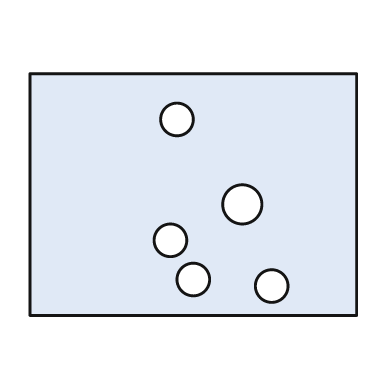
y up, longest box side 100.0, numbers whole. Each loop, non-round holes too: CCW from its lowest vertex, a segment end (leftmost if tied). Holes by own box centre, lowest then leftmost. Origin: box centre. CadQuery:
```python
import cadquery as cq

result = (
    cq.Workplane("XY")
    .moveTo(-50.0, -37.0)
    .lineTo(50.0, -37.0)
    .lineTo(50.0, 37.0)
    .lineTo(-50.0, 37.0)
    .close()
    .moveTo(24.0, -28.0)
    .circle(5.0)
    .moveTo(0.0, -26.0)
    .circle(5.0)
    .moveTo(-7.0, -14.0)
    .circle(5.0)
    .moveTo(15.0, -3.0)
    .circle(6.0)
    .moveTo(-5.0, 23.0)
    .circle(5.0)
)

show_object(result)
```